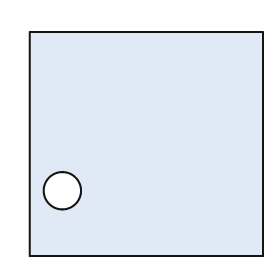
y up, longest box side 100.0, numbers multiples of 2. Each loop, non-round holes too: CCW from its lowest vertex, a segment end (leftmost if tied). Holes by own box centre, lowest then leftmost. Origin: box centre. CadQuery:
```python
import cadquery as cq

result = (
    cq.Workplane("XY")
    .moveTo(-50.0, -48.0)
    .lineTo(50.0, -48.0)
    .lineTo(50.0, 48.0)
    .lineTo(-50.0, 48.0)
    .close()
    .moveTo(-36.0, -20.0)
    .circle(8.0)
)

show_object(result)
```